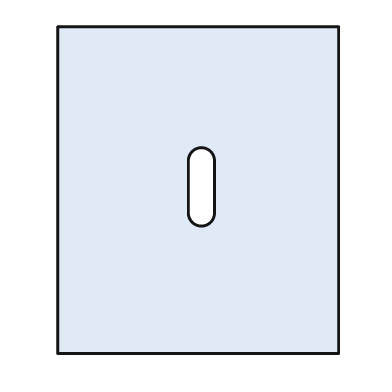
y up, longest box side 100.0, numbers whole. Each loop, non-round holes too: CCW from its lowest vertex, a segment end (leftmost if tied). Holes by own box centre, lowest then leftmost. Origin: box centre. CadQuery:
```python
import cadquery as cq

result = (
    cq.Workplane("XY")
    .moveTo(-43.0, -50.0)
    .lineTo(43.0, -50.0)
    .lineTo(43.0, 50.0)
    .lineTo(-43.0, 50.0)
    .close()
    .moveTo(-3.0, -7.0)
    .threePointArc((1.0, -11.0), (5.0, -7.0))
    .lineTo(5.0, 9.0)
    .threePointArc((1.0, 13.0), (-3.0, 9.0))
    .close()
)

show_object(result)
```